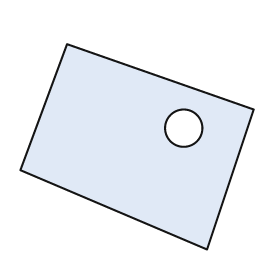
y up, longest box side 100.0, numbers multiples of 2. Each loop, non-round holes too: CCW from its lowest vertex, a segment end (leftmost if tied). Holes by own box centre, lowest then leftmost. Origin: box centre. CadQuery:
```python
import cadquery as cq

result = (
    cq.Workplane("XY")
    .moveTo(30.0, -44.0)
    .lineTo(50.0, 16.0)
    .lineTo(-30.0, 44.0)
    .lineTo(-50.0, -10.0)
    .close()
    .moveTo(20.0, 8.0)
    .circle(8.0)
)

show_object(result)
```